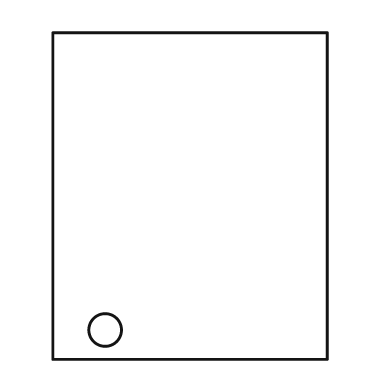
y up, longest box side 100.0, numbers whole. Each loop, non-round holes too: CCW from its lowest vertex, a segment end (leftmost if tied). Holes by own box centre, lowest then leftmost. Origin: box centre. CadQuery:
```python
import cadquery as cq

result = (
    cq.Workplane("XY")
    .moveTo(-42.0, -50.0)
    .lineTo(42.0, -50.0)
    .lineTo(42.0, 50.0)
    .lineTo(-42.0, 50.0)
    .close()
    .moveTo(-26.0, -41.0)
    .circle(5.0)
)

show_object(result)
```